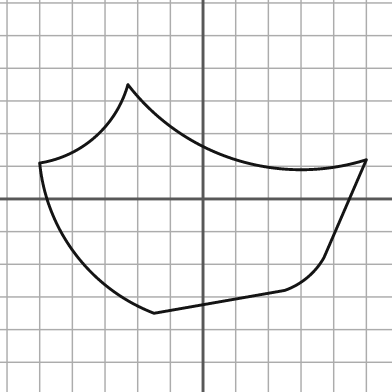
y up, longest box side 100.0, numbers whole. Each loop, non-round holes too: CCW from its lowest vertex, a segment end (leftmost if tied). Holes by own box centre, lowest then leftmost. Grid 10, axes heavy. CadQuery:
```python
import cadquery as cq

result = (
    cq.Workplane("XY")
    .moveTo(-15.0, -35.0)
    .lineTo(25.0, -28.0)
    .threePointArc((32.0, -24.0), (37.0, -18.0))
    .lineTo(50.0, 12.0)
    .threePointArc((10.0, 12.0), (-23.0, 35.0))
    .threePointArc((-33.0, 19.0), (-50.0, 11.0))
    .threePointArc((-39.0, -17.0), (-15.0, -35.0))
    .close()
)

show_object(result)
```